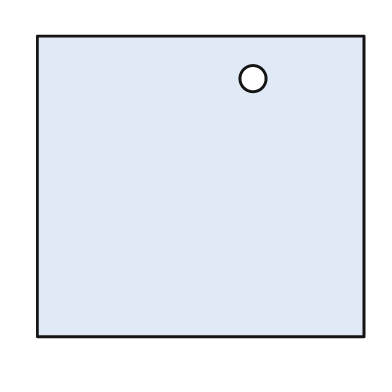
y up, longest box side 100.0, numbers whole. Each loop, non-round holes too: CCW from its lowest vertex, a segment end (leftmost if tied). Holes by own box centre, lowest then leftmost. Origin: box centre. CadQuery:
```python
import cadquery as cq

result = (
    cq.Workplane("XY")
    .moveTo(-50.0, -46.0)
    .lineTo(50.0, -46.0)
    .lineTo(50.0, 46.0)
    .lineTo(-50.0, 46.0)
    .close()
    .moveTo(16.0, 33.0)
    .circle(4.0)
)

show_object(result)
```